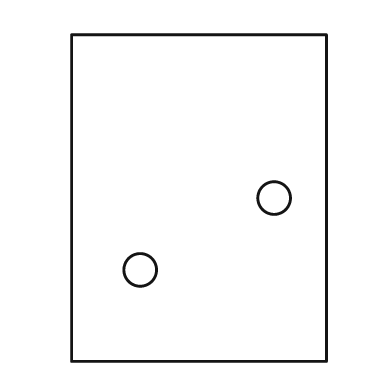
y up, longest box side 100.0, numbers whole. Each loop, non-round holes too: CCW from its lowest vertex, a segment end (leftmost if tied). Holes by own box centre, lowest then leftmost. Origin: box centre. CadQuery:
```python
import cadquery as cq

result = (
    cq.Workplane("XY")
    .moveTo(-39.0, -50.0)
    .lineTo(39.0, -50.0)
    .lineTo(39.0, 50.0)
    .lineTo(-39.0, 50.0)
    .close()
    .moveTo(-18.0, -22.0)
    .circle(5.0)
    .moveTo(23.0, 0.0)
    .circle(5.0)
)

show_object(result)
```